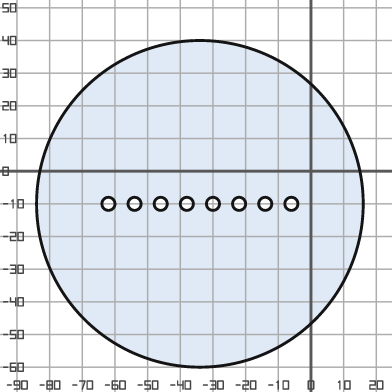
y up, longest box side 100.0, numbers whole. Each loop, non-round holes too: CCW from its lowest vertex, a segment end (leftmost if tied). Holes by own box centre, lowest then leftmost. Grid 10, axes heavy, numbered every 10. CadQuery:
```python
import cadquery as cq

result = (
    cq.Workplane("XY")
    .moveTo(-34.0, -10.0)
    .circle(50.0)
    .moveTo(-62.0, -10.0)
    .circle(2.0)
    .moveTo(-54.0, -10.0)
    .circle(2.0)
    .moveTo(-46.0, -10.0)
    .circle(2.0)
    .moveTo(-38.0, -10.0)
    .circle(2.0)
    .moveTo(-30.0, -10.0)
    .circle(2.0)
    .moveTo(-22.0, -10.0)
    .circle(2.0)
    .moveTo(-14.0, -10.0)
    .circle(2.0)
    .moveTo(-6.0, -10.0)
    .circle(2.0)
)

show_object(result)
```